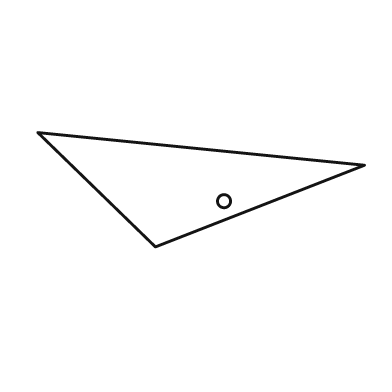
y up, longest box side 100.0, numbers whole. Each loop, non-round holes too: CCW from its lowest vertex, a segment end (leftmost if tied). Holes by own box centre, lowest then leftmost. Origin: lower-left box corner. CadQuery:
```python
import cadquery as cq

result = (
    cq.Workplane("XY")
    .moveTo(36.0, 0.0)
    .lineTo(100.0, 25.0)
    .lineTo(0.0, 35.0)
    .close()
    .moveTo(57.0, 14.0)
    .circle(2.0)
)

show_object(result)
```